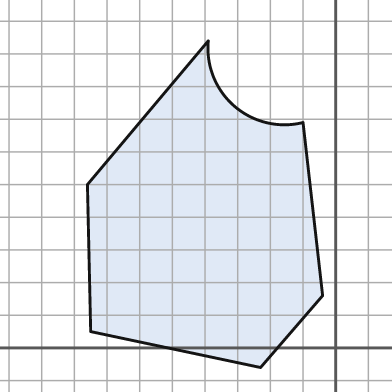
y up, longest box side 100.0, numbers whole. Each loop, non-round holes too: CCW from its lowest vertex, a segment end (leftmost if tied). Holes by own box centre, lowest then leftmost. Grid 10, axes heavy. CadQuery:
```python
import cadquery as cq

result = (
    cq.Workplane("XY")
    .moveTo(-23.0, -6.0)
    .lineTo(-4.0, 16.0)
    .lineTo(-10.0, 69.0)
    .threePointArc((-31.0, 74.0), (-39.0, 94.0))
    .lineTo(-76.0, 50.0)
    .lineTo(-75.0, 5.0)
    .close()
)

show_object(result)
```